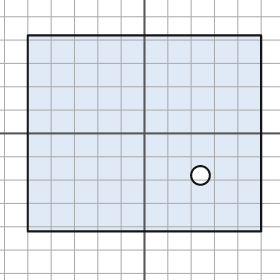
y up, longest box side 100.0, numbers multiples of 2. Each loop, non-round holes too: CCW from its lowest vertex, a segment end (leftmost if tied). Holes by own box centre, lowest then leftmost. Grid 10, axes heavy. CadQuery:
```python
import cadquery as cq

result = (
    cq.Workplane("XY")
    .moveTo(-50.0, -42.0)
    .lineTo(50.0, -42.0)
    .lineTo(50.0, 42.0)
    .lineTo(-50.0, 42.0)
    .close()
    .moveTo(24.0, -18.0)
    .circle(4.0)
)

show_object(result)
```